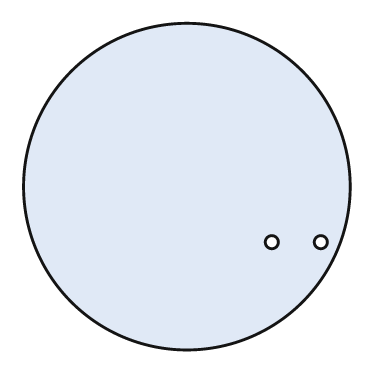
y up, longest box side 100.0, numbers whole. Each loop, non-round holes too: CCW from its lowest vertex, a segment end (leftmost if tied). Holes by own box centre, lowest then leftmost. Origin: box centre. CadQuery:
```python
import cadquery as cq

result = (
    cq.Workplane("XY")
    .moveTo(0.0, 0.0)
    .circle(50.0)
    .moveTo(26.0, -17.0)
    .circle(2.0)
    .moveTo(41.0, -17.0)
    .circle(2.0)
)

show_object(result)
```